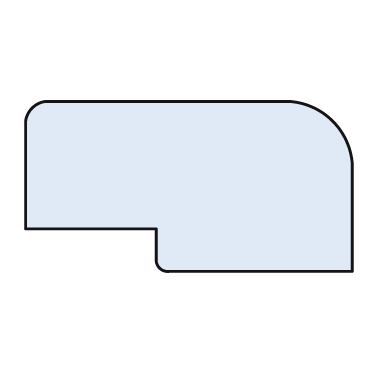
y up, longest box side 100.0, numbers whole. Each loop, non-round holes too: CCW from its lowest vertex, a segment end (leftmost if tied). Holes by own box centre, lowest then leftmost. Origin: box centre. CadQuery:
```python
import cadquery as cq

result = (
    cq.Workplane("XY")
    .moveTo(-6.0, -26.0)
    .lineTo(50.0, -26.0)
    .lineTo(50.0, 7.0)
    .threePointArc((44.0, 20.0), (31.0, 26.0))
    .lineTo(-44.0, 26.0)
    .threePointArc((-48.0, 24.0), (-50.0, 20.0))
    .lineTo(-50.0, -13.0)
    .lineTo(-10.0, -13.0)
    .lineTo(-10.0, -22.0)
    .threePointArc((-9.0, -25.0), (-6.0, -26.0))
    .close()
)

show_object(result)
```